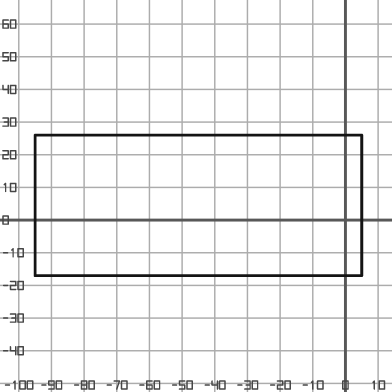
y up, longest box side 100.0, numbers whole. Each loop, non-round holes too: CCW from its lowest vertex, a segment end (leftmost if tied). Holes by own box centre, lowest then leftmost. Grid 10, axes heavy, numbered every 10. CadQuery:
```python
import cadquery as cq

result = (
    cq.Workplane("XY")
    .moveTo(-95.0, -17.0)
    .lineTo(5.0, -17.0)
    .lineTo(5.0, 26.0)
    .lineTo(-95.0, 26.0)
    .close()
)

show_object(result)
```